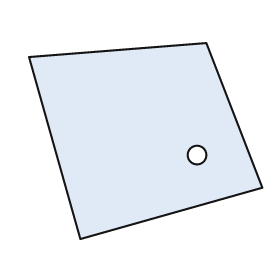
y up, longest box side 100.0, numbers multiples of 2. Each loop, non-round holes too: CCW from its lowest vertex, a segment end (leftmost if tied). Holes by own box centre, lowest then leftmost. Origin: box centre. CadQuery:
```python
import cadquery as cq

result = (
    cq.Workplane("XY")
    .moveTo(-28.0, -42.0)
    .lineTo(50.0, -20.0)
    .lineTo(26.0, 42.0)
    .lineTo(-50.0, 36.0)
    .close()
    .moveTo(22.0, -6.0)
    .circle(4.0)
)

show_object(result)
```